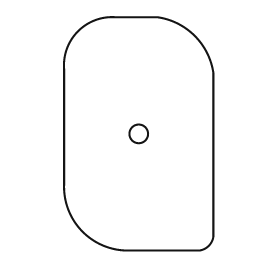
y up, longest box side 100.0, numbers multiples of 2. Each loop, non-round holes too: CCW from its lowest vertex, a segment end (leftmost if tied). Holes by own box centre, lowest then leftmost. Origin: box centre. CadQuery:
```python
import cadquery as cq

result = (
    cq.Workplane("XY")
    .moveTo(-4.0, -50.0)
    .lineTo(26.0, -50.0)
    .threePointArc((30.0, -48.0), (32.0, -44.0))
    .lineTo(32.0, 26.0)
    .threePointArc((24.0, 42.0), (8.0, 50.0))
    .lineTo(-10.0, 50.0)
    .threePointArc((-26.0, 44.0), (-32.0, 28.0))
    .lineTo(-32.0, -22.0)
    .threePointArc((-24.0, -42.0), (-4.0, -50.0))
    .close()
    .moveTo(0.0, 0.0)
    .circle(4.0)
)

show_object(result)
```